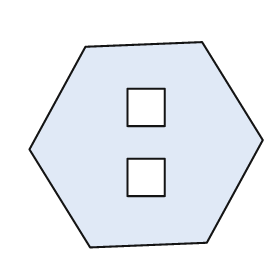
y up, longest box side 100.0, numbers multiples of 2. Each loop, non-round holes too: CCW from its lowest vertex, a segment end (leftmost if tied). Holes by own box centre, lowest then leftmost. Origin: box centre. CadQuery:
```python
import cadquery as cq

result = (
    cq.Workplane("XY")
    .moveTo(-24.0, -44.0)
    .lineTo(26.0, -42.0)
    .lineTo(50.0, 2.0)
    .lineTo(24.0, 44.0)
    .lineTo(-26.0, 42.0)
    .lineTo(-50.0, -2.0)
    .close()
    .moveTo(-8.0, -22.0)
    .lineTo(8.0, -22.0)
    .lineTo(8.0, -6.0)
    .lineTo(-8.0, -6.0)
    .close()
    .moveTo(-8.0, 8.0)
    .lineTo(8.0, 8.0)
    .lineTo(8.0, 24.0)
    .lineTo(-8.0, 24.0)
    .close()
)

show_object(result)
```